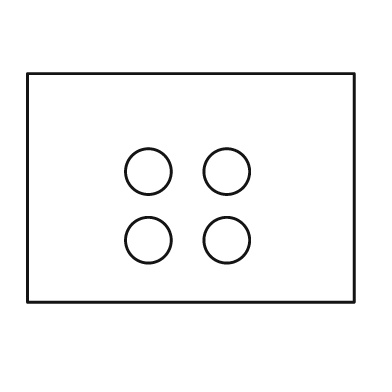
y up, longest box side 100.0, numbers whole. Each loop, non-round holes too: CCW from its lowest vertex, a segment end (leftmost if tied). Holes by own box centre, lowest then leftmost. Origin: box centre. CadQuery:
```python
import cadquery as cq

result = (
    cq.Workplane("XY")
    .moveTo(-50.0, -35.0)
    .lineTo(50.0, -35.0)
    .lineTo(50.0, 35.0)
    .lineTo(-50.0, 35.0)
    .close()
    .moveTo(-13.0, -16.0)
    .circle(7.0)
    .moveTo(11.0, -16.0)
    .circle(7.0)
    .moveTo(-13.0, 5.0)
    .circle(7.0)
    .moveTo(11.0, 5.0)
    .circle(7.0)
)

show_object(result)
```